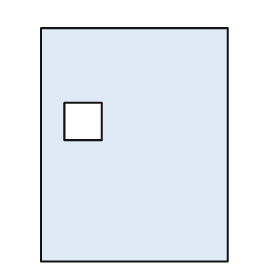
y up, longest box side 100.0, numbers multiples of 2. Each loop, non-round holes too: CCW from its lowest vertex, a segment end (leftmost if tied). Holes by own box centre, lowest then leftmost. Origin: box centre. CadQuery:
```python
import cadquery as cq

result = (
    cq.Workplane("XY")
    .moveTo(-40.0, -50.0)
    .lineTo(40.0, -50.0)
    .lineTo(40.0, 50.0)
    .lineTo(-40.0, 50.0)
    .close()
    .moveTo(-30.0, 2.0)
    .lineTo(-14.0, 2.0)
    .lineTo(-14.0, 18.0)
    .lineTo(-30.0, 18.0)
    .close()
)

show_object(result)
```